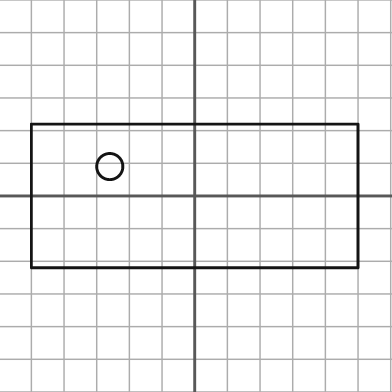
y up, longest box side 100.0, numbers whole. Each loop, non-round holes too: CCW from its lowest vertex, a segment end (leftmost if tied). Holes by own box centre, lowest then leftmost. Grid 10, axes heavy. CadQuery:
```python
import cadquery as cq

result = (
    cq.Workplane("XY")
    .moveTo(-50.0, -22.0)
    .lineTo(50.0, -22.0)
    .lineTo(50.0, 22.0)
    .lineTo(-50.0, 22.0)
    .close()
    .moveTo(-26.0, 9.0)
    .circle(4.0)
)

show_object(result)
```